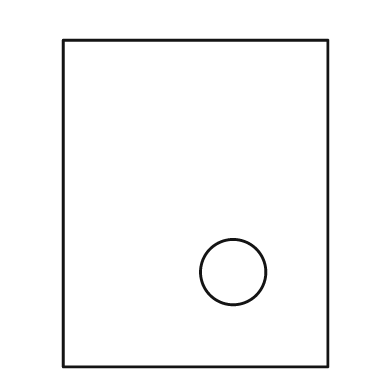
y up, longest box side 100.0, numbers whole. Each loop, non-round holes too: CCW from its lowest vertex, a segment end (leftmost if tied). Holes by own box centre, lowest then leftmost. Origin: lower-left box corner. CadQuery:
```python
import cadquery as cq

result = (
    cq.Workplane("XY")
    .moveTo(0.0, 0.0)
    .lineTo(81.0, 0.0)
    .lineTo(81.0, 100.0)
    .lineTo(0.0, 100.0)
    .close()
    .moveTo(52.0, 29.0)
    .circle(10.0)
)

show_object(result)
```